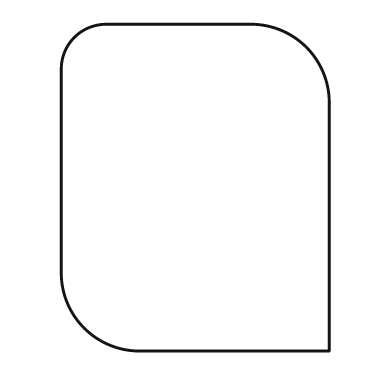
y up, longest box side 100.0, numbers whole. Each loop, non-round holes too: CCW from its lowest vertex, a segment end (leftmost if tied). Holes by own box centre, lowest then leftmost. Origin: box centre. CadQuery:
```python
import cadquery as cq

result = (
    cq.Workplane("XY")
    .moveTo(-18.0, -50.0)
    .lineTo(41.0, -50.0)
    .lineTo(41.0, 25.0)
    .threePointArc((34.0, 43.0), (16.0, 50.0))
    .lineTo(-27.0, 50.0)
    .threePointArc((-37.0, 46.0), (-41.0, 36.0))
    .lineTo(-41.0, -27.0)
    .threePointArc((-34.0, -43.0), (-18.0, -50.0))
    .close()
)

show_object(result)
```